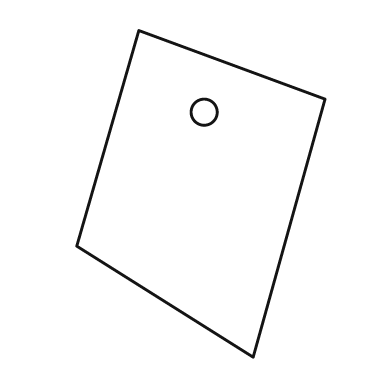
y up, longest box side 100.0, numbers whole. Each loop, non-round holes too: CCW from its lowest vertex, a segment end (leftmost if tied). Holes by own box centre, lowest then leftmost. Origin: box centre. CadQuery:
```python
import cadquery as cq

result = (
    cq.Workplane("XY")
    .moveTo(16.0, -50.0)
    .lineTo(38.0, 29.0)
    .lineTo(-19.0, 50.0)
    .lineTo(-38.0, -16.0)
    .close()
    .moveTo(1.0, 25.0)
    .circle(4.0)
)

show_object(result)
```